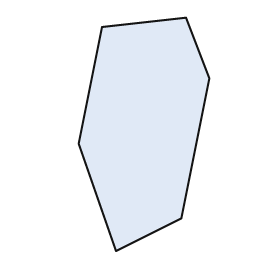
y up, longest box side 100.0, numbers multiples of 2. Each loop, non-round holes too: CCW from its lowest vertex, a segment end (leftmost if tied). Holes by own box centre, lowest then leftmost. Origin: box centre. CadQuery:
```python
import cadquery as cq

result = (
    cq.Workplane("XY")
    .moveTo(-12.0, -50.0)
    .lineTo(16.0, -36.0)
    .lineTo(28.0, 24.0)
    .lineTo(18.0, 50.0)
    .lineTo(-18.0, 46.0)
    .lineTo(-28.0, -4.0)
    .close()
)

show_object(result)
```